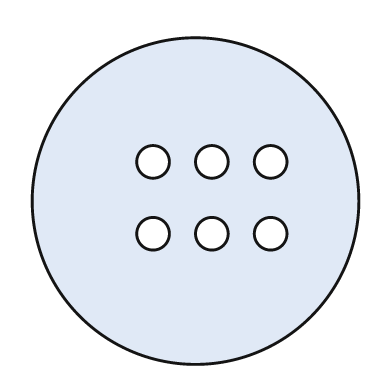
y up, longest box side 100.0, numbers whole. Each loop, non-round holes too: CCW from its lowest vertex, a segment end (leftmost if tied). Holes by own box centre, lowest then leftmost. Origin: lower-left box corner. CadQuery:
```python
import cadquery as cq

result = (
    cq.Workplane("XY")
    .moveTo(50.0, 50.0)
    .circle(50.0)
    .moveTo(37.0, 40.0)
    .circle(5.0)
    .moveTo(55.0, 40.0)
    .circle(5.0)
    .moveTo(73.0, 40.0)
    .circle(5.0)
    .moveTo(37.0, 62.0)
    .circle(5.0)
    .moveTo(55.0, 62.0)
    .circle(5.0)
    .moveTo(73.0, 62.0)
    .circle(5.0)
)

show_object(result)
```